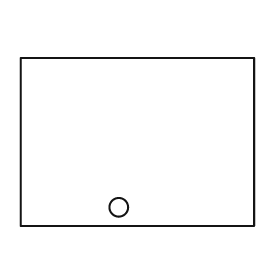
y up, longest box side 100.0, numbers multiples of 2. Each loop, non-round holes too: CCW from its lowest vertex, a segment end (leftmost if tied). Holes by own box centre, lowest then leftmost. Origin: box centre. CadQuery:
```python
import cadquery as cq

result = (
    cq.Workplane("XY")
    .moveTo(-50.0, -36.0)
    .lineTo(50.0, -36.0)
    .lineTo(50.0, 36.0)
    .lineTo(-50.0, 36.0)
    .close()
    .moveTo(-8.0, -28.0)
    .circle(4.0)
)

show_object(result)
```